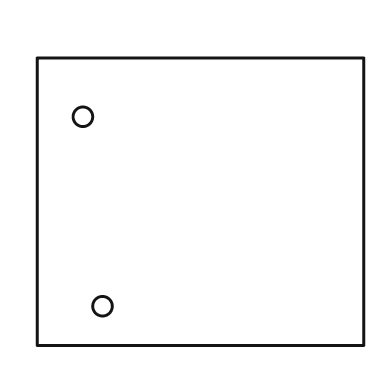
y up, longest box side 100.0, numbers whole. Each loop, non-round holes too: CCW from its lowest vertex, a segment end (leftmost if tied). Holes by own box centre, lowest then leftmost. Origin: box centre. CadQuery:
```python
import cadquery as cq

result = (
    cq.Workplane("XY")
    .moveTo(-50.0, -44.0)
    .lineTo(50.0, -44.0)
    .lineTo(50.0, 44.0)
    .lineTo(-50.0, 44.0)
    .close()
    .moveTo(-30.0, -32.0)
    .circle(3.0)
    .moveTo(-36.0, 26.0)
    .circle(3.0)
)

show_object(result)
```